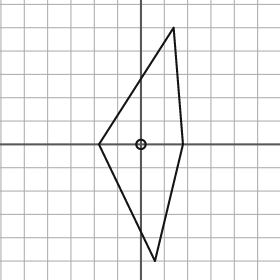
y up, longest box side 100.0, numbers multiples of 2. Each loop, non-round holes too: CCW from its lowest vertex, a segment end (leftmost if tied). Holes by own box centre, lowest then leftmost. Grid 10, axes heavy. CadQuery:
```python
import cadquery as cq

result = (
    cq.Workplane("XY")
    .moveTo(6.0, -50.0)
    .lineTo(18.0, 0.0)
    .lineTo(14.0, 50.0)
    .lineTo(-18.0, 0.0)
    .close()
    .moveTo(0.0, 0.0)
    .circle(2.0)
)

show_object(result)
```